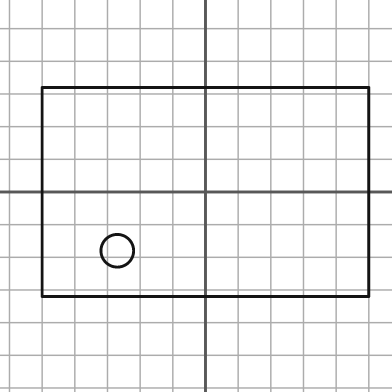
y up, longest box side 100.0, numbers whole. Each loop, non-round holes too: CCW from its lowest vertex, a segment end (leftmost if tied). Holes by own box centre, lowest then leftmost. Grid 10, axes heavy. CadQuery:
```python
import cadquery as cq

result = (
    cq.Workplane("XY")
    .moveTo(-50.0, -32.0)
    .lineTo(50.0, -32.0)
    .lineTo(50.0, 32.0)
    .lineTo(-50.0, 32.0)
    .close()
    .moveTo(-27.0, -18.0)
    .circle(5.0)
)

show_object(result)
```